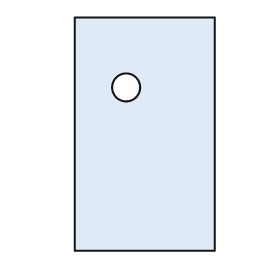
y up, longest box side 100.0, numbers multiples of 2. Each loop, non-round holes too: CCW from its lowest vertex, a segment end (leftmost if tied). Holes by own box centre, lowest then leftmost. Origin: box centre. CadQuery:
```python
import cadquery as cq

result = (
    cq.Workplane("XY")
    .moveTo(-30.0, -50.0)
    .lineTo(30.0, -50.0)
    .lineTo(30.0, 50.0)
    .lineTo(-30.0, 50.0)
    .close()
    .moveTo(-8.0, 20.0)
    .circle(6.0)
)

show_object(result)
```